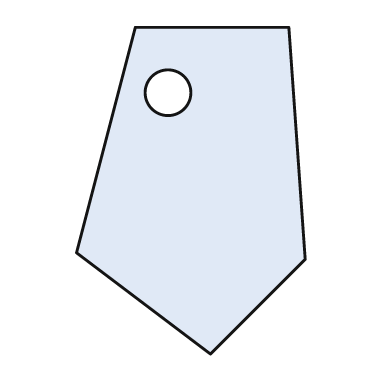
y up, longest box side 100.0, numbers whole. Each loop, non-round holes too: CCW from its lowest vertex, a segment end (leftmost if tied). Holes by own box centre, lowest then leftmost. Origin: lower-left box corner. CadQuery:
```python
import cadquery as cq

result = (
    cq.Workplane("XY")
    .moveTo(41.0, 0.0)
    .lineTo(70.0, 29.0)
    .lineTo(65.0, 100.0)
    .lineTo(18.0, 100.0)
    .lineTo(0.0, 31.0)
    .close()
    .moveTo(28.0, 80.0)
    .circle(7.0)
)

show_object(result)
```